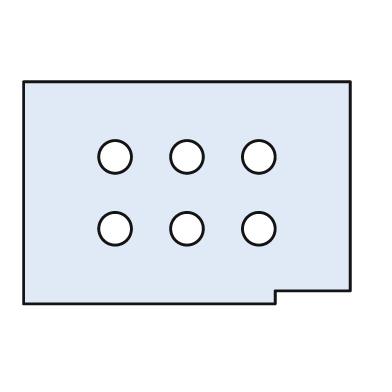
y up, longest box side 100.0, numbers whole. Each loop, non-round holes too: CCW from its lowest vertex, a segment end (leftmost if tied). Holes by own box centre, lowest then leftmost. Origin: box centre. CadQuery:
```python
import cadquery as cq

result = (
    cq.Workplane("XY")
    .moveTo(-50.0, -34.0)
    .lineTo(27.0, -34.0)
    .lineTo(27.0, -30.0)
    .lineTo(50.0, -30.0)
    .lineTo(50.0, 34.0)
    .lineTo(-50.0, 34.0)
    .close()
    .moveTo(-22.0, -11.0)
    .circle(5.0)
    .moveTo(0.0, -11.0)
    .circle(5.0)
    .moveTo(22.0, -11.0)
    .circle(5.0)
    .moveTo(-22.0, 11.0)
    .circle(5.0)
    .moveTo(0.0, 11.0)
    .circle(5.0)
    .moveTo(22.0, 11.0)
    .circle(5.0)
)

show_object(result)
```